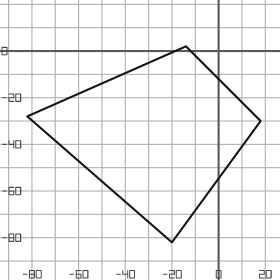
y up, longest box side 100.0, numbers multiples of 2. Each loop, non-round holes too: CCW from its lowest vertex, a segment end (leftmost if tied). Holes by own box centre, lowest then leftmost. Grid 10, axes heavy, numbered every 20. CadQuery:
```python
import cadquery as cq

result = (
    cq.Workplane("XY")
    .moveTo(-20.0, -82.0)
    .lineTo(18.0, -30.0)
    .lineTo(-14.0, 2.0)
    .lineTo(-82.0, -28.0)
    .close()
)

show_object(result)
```